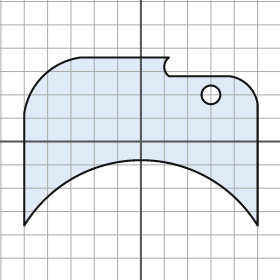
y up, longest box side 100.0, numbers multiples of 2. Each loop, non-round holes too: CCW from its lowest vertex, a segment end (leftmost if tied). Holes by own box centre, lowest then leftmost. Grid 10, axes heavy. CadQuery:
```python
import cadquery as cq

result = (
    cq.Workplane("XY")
    .moveTo(-50.0, -36.0)
    .threePointArc((0.0, -8.0), (50.0, -36.0))
    .lineTo(50.0, 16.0)
    .threePointArc((46.0, 24.0), (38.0, 28.0))
    .lineTo(12.0, 28.0)
    .threePointArc((10.0, 32.0), (12.0, 36.0))
    .lineTo(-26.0, 36.0)
    .threePointArc((-42.0, 28.0), (-50.0, 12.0))
    .close()
    .moveTo(30.0, 20.0)
    .circle(4.0)
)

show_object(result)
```